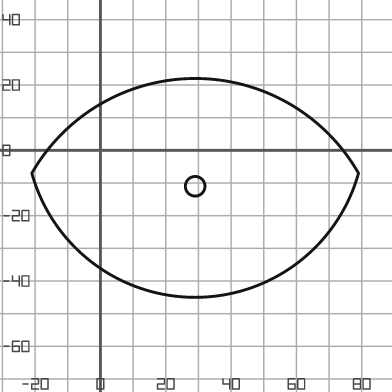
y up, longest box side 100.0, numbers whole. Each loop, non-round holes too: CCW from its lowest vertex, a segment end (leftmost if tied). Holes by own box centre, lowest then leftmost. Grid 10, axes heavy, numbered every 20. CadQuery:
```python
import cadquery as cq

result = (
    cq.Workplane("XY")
    .moveTo(-21.0, -7.0)
    .threePointArc((29.0, -45.0), (79.0, -7.0))
    .threePointArc((29.0, 22.0), (-21.0, -7.0))
    .close()
    .moveTo(29.0, -11.0)
    .circle(3.0)
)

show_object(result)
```